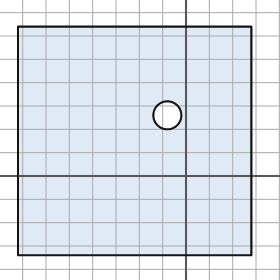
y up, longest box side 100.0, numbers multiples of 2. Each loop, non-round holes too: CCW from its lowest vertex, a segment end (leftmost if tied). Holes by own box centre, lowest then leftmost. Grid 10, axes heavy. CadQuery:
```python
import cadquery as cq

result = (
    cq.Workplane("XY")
    .moveTo(-72.0, -34.0)
    .lineTo(28.0, -34.0)
    .lineTo(28.0, 64.0)
    .lineTo(-72.0, 64.0)
    .close()
    .moveTo(-8.0, 26.0)
    .circle(6.0)
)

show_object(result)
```